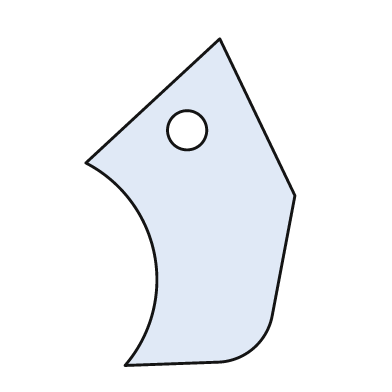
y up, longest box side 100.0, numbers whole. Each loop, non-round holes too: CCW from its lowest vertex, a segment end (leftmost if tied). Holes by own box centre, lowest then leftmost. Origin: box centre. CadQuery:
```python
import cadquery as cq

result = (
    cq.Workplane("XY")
    .moveTo(-20.0, -50.0)
    .lineTo(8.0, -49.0)
    .threePointArc((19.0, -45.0), (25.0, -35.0))
    .lineTo(32.0, 2.0)
    .lineTo(9.0, 50.0)
    .lineTo(-32.0, 12.0)
    .threePointArc((-11.0, -16.0), (-20.0, -50.0))
    .close()
    .moveTo(-1.0, 22.0)
    .circle(6.0)
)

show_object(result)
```